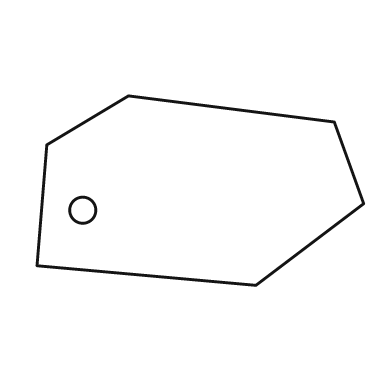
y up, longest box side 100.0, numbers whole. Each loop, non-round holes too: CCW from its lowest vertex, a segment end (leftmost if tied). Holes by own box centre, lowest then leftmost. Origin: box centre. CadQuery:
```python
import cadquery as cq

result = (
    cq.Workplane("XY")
    .moveTo(17.0, -29.0)
    .lineTo(50.0, -4.0)
    .lineTo(41.0, 21.0)
    .lineTo(-22.0, 29.0)
    .lineTo(-47.0, 14.0)
    .lineTo(-50.0, -23.0)
    .close()
    .moveTo(-36.0, -6.0)
    .circle(4.0)
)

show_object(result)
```